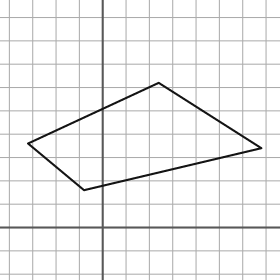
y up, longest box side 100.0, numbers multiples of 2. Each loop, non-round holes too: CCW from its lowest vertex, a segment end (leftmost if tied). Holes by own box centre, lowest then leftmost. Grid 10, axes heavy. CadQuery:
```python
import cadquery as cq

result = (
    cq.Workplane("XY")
    .moveTo(-8.0, 16.0)
    .lineTo(68.0, 34.0)
    .lineTo(24.0, 62.0)
    .lineTo(-32.0, 36.0)
    .close()
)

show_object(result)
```